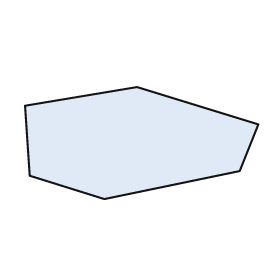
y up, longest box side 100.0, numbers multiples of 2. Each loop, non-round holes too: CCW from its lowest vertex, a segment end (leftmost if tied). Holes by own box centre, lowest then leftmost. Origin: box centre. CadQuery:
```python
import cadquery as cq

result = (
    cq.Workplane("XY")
    .moveTo(-16.0, -24.0)
    .lineTo(42.0, -12.0)
    .lineTo(50.0, 8.0)
    .lineTo(-2.0, 24.0)
    .lineTo(-50.0, 16.0)
    .lineTo(-48.0, -14.0)
    .close()
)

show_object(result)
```